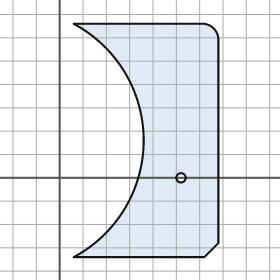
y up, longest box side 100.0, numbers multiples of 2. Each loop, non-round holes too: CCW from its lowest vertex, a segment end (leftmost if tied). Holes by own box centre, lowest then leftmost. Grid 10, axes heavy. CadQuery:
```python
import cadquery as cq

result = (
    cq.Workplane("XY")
    .moveTo(6.0, -34.0)
    .lineTo(62.0, -34.0)
    .lineTo(68.0, -28.0)
    .lineTo(68.0, 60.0)
    .threePointArc((66.0, 64.0), (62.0, 66.0))
    .lineTo(6.0, 66.0)
    .threePointArc((36.0, 16.0), (6.0, -34.0))
    .close()
    .moveTo(52.0, 0.0)
    .circle(2.0)
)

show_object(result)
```